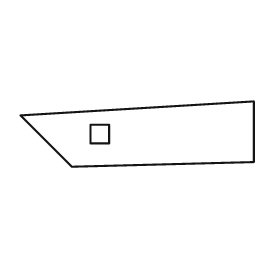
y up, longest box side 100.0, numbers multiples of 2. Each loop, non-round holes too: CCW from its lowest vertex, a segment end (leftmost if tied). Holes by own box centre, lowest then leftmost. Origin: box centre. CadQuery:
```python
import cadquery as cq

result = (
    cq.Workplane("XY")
    .moveTo(-28.0, -14.0)
    .lineTo(50.0, -12.0)
    .lineTo(50.0, 14.0)
    .lineTo(-50.0, 8.0)
    .close()
    .moveTo(-20.0, -4.0)
    .lineTo(-12.0, -4.0)
    .lineTo(-12.0, 4.0)
    .lineTo(-20.0, 4.0)
    .close()
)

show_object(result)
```